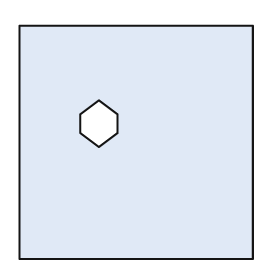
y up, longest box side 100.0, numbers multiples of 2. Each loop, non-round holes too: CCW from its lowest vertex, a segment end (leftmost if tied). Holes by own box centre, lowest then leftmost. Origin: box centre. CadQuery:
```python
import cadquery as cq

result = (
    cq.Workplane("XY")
    .moveTo(-50.0, -50.0)
    .lineTo(50.0, -50.0)
    .lineTo(50.0, 50.0)
    .lineTo(-50.0, 50.0)
    .close()
    .moveTo(-16.0, -2.0)
    .lineTo(-8.0, 4.0)
    .lineTo(-8.0, 12.0)
    .lineTo(-16.0, 18.0)
    .lineTo(-24.0, 12.0)
    .lineTo(-24.0, 4.0)
    .close()
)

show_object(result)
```